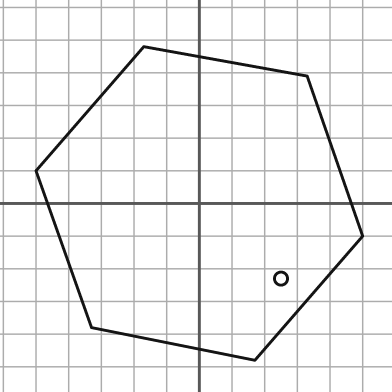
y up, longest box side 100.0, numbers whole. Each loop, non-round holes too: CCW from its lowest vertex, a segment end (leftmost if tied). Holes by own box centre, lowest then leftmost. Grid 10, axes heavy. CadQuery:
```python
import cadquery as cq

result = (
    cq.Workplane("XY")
    .moveTo(17.0, -48.0)
    .lineTo(50.0, -10.0)
    .lineTo(33.0, 39.0)
    .lineTo(-17.0, 48.0)
    .lineTo(-50.0, 10.0)
    .lineTo(-33.0, -38.0)
    .close()
    .moveTo(25.0, -23.0)
    .circle(2.0)
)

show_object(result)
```